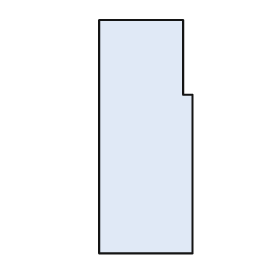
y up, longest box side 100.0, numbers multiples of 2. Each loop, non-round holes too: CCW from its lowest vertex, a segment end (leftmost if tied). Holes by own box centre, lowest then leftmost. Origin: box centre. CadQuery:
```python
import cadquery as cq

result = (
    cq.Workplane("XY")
    .moveTo(-20.0, -50.0)
    .lineTo(20.0, -50.0)
    .lineTo(20.0, 18.0)
    .lineTo(16.0, 18.0)
    .lineTo(16.0, 50.0)
    .lineTo(-20.0, 50.0)
    .close()
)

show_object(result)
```